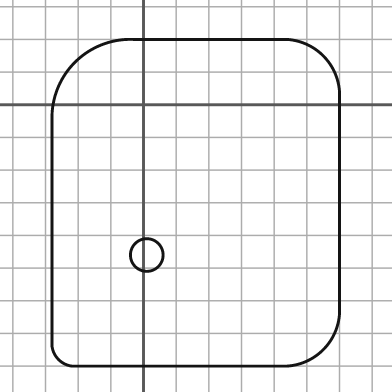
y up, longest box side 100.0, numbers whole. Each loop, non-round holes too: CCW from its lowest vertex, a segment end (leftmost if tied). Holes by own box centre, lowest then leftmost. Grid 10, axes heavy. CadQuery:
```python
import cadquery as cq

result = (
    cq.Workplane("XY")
    .moveTo(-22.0, -80.0)
    .lineTo(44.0, -80.0)
    .threePointArc((55.0, -75.0), (60.0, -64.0))
    .lineTo(60.0, 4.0)
    .threePointArc((55.0, 15.0), (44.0, 20.0))
    .lineTo(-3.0, 20.0)
    .threePointArc((-21.0, 13.0), (-28.0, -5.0))
    .lineTo(-28.0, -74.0)
    .threePointArc((-26.0, -78.0), (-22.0, -80.0))
    .close()
    .moveTo(1.0, -46.0)
    .circle(5.0)
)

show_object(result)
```